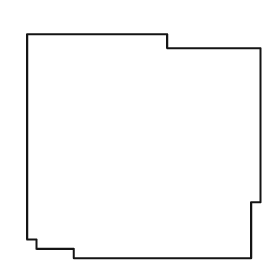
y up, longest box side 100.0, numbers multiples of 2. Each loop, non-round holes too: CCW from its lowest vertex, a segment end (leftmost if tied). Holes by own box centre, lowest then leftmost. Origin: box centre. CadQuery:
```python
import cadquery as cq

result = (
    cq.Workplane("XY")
    .moveTo(-30.0, -48.0)
    .lineTo(46.0, -48.0)
    .lineTo(46.0, -24.0)
    .lineTo(50.0, -24.0)
    .lineTo(50.0, 42.0)
    .lineTo(10.0, 42.0)
    .lineTo(10.0, 48.0)
    .lineTo(-50.0, 48.0)
    .lineTo(-50.0, -40.0)
    .lineTo(-46.0, -40.0)
    .lineTo(-46.0, -44.0)
    .lineTo(-30.0, -44.0)
    .close()
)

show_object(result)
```